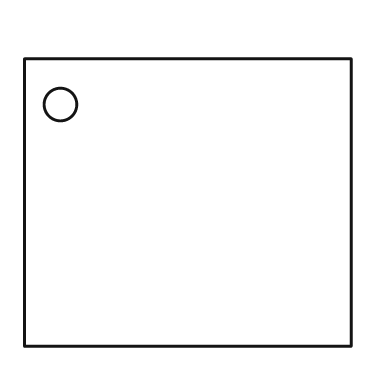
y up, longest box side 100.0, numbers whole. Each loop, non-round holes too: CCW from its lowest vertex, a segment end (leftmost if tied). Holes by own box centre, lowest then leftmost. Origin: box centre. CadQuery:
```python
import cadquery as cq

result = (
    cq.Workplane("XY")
    .moveTo(-50.0, -44.0)
    .lineTo(50.0, -44.0)
    .lineTo(50.0, 44.0)
    .lineTo(-50.0, 44.0)
    .close()
    .moveTo(-39.0, 30.0)
    .circle(5.0)
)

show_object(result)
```